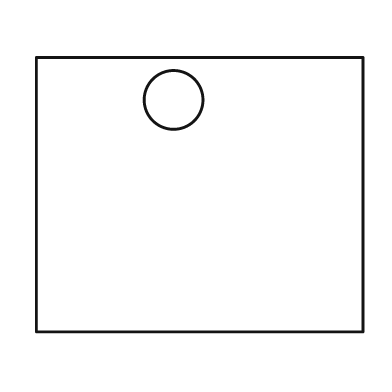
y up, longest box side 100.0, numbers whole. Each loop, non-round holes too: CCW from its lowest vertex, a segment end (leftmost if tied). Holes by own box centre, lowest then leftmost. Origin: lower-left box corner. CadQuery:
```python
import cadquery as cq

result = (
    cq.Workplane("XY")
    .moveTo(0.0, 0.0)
    .lineTo(100.0, 0.0)
    .lineTo(100.0, 84.0)
    .lineTo(0.0, 84.0)
    .close()
    .moveTo(42.0, 71.0)
    .circle(9.0)
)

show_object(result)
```